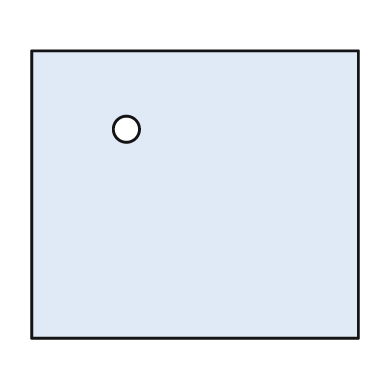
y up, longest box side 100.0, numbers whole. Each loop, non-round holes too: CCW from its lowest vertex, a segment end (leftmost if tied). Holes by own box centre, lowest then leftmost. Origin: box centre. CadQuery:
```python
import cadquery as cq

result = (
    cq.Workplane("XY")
    .moveTo(-50.0, -44.0)
    .lineTo(50.0, -44.0)
    .lineTo(50.0, 44.0)
    .lineTo(-50.0, 44.0)
    .close()
    .moveTo(-21.0, 20.0)
    .circle(4.0)
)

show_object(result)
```